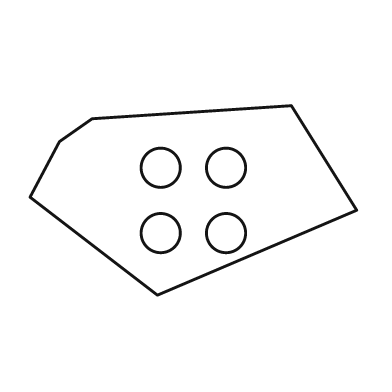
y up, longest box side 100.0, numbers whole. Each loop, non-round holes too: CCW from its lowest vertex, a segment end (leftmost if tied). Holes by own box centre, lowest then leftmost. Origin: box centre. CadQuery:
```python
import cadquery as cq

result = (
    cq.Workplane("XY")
    .moveTo(-11.0, -29.0)
    .lineTo(50.0, -3.0)
    .lineTo(30.0, 29.0)
    .lineTo(-31.0, 25.0)
    .lineTo(-41.0, 18.0)
    .lineTo(-50.0, 1.0)
    .close()
    .moveTo(-10.0, -10.0)
    .circle(6.0)
    .moveTo(10.0, -10.0)
    .circle(6.0)
    .moveTo(-10.0, 10.0)
    .circle(6.0)
    .moveTo(10.0, 10.0)
    .circle(6.0)
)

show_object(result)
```